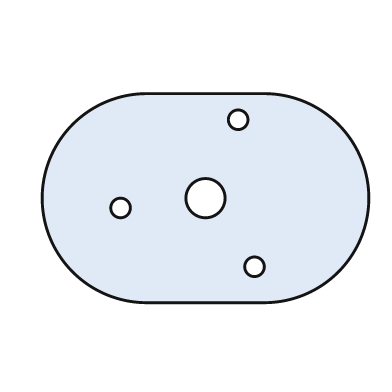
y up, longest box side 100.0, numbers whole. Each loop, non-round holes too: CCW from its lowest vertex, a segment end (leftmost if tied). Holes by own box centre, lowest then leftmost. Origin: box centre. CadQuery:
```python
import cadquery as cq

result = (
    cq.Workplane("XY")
    .moveTo(-18.0, -32.0)
    .lineTo(18.0, -32.0)
    .threePointArc((50.0, 0.0), (18.0, 32.0))
    .lineTo(-18.0, 32.0)
    .threePointArc((-50.0, 0.0), (-18.0, -32.0))
    .close()
    .moveTo(15.0, -21.0)
    .circle(3.0)
    .moveTo(-26.0, -3.0)
    .circle(3.0)
    .moveTo(0.0, 0.0)
    .circle(6.0)
    .moveTo(10.0, 24.0)
    .circle(3.0)
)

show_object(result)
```